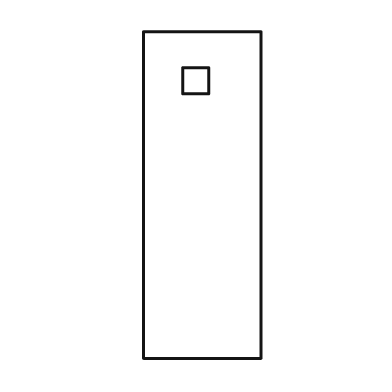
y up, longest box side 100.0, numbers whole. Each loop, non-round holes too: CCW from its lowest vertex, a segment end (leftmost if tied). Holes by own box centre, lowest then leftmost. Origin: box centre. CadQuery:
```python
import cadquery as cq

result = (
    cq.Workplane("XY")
    .moveTo(-18.0, -50.0)
    .lineTo(18.0, -50.0)
    .lineTo(18.0, 50.0)
    .lineTo(-18.0, 50.0)
    .close()
    .moveTo(-6.0, 31.0)
    .lineTo(2.0, 31.0)
    .lineTo(2.0, 39.0)
    .lineTo(-6.0, 39.0)
    .close()
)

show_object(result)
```